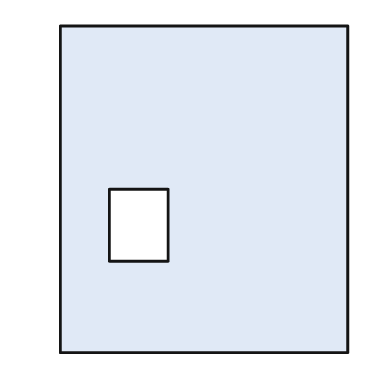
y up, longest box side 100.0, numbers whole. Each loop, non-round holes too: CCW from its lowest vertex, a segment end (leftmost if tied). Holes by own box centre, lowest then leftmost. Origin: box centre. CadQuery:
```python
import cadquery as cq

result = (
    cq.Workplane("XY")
    .moveTo(-44.0, -50.0)
    .lineTo(44.0, -50.0)
    .lineTo(44.0, 50.0)
    .lineTo(-44.0, 50.0)
    .close()
    .moveTo(-29.0, -22.0)
    .lineTo(-11.0, -22.0)
    .lineTo(-11.0, 0.0)
    .lineTo(-29.0, 0.0)
    .close()
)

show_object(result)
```